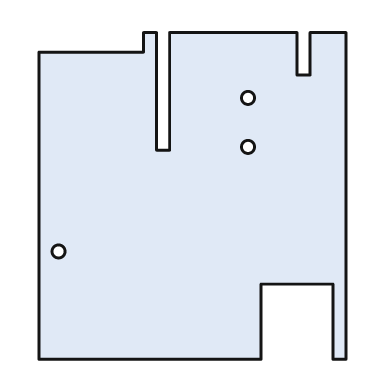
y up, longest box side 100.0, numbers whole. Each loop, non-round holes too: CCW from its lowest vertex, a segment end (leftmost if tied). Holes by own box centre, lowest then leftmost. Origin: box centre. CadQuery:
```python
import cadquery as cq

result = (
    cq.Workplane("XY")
    .moveTo(-47.0, -50.0)
    .lineTo(21.0, -50.0)
    .lineTo(21.0, -27.0)
    .lineTo(43.0, -27.0)
    .lineTo(43.0, -50.0)
    .lineTo(47.0, -50.0)
    .lineTo(47.0, 50.0)
    .lineTo(36.0, 50.0)
    .lineTo(36.0, 37.0)
    .lineTo(32.0, 37.0)
    .lineTo(32.0, 50.0)
    .lineTo(-7.0, 50.0)
    .lineTo(-7.0, 14.0)
    .lineTo(-11.0, 14.0)
    .lineTo(-11.0, 50.0)
    .lineTo(-15.0, 50.0)
    .lineTo(-15.0, 44.0)
    .lineTo(-47.0, 44.0)
    .close()
    .moveTo(-41.0, -17.0)
    .circle(2.0)
    .moveTo(17.0, 15.0)
    .circle(2.0)
    .moveTo(17.0, 30.0)
    .circle(2.0)
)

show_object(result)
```